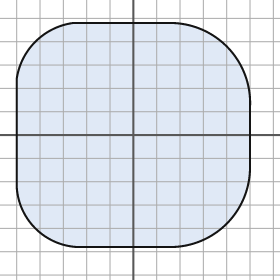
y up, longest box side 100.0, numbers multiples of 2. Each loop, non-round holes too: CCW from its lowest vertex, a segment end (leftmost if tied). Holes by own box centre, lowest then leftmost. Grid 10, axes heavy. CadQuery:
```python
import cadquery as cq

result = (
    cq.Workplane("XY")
    .moveTo(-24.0, -48.0)
    .lineTo(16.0, -48.0)
    .threePointArc((40.0, -38.0), (50.0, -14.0))
    .lineTo(50.0, 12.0)
    .threePointArc((40.0, 38.0), (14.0, 48.0))
    .lineTo(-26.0, 48.0)
    .threePointArc((-42.0, 40.0), (-50.0, 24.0))
    .lineTo(-50.0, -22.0)
    .threePointArc((-42.0, -40.0), (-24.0, -48.0))
    .close()
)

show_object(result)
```